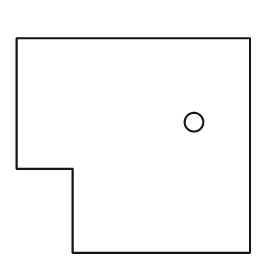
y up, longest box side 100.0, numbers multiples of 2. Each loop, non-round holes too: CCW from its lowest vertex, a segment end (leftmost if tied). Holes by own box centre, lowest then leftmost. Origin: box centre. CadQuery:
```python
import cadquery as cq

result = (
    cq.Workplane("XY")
    .moveTo(-26.0, -46.0)
    .lineTo(50.0, -46.0)
    .lineTo(50.0, 46.0)
    .lineTo(-50.0, 46.0)
    .lineTo(-50.0, -10.0)
    .lineTo(-26.0, -10.0)
    .close()
    .moveTo(26.0, 10.0)
    .circle(4.0)
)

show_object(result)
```